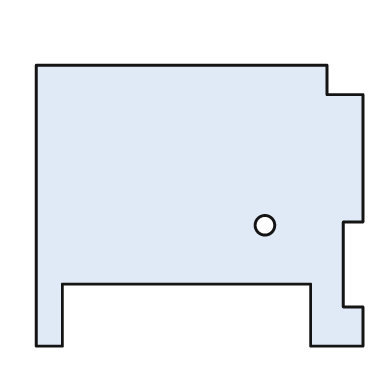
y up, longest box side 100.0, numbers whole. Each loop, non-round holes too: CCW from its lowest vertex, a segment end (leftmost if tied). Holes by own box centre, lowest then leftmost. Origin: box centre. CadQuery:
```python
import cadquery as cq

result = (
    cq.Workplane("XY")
    .moveTo(-50.0, -43.0)
    .lineTo(-42.0, -43.0)
    .lineTo(-42.0, -24.0)
    .lineTo(34.0, -24.0)
    .lineTo(34.0, -43.0)
    .lineTo(50.0, -43.0)
    .lineTo(50.0, -31.0)
    .lineTo(44.0, -31.0)
    .lineTo(44.0, -5.0)
    .lineTo(50.0, -5.0)
    .lineTo(50.0, 34.0)
    .lineTo(39.0, 34.0)
    .lineTo(39.0, 43.0)
    .lineTo(-50.0, 43.0)
    .close()
    .moveTo(20.0, -6.0)
    .circle(3.0)
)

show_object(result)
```